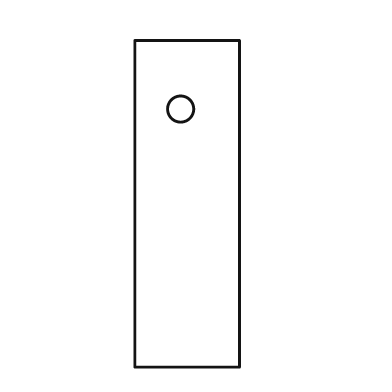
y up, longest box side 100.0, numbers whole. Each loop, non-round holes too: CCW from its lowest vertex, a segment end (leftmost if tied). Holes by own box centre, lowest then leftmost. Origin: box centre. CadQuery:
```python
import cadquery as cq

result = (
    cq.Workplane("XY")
    .moveTo(-16.0, -50.0)
    .lineTo(16.0, -50.0)
    .lineTo(16.0, 50.0)
    .lineTo(-16.0, 50.0)
    .close()
    .moveTo(-2.0, 29.0)
    .circle(4.0)
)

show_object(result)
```